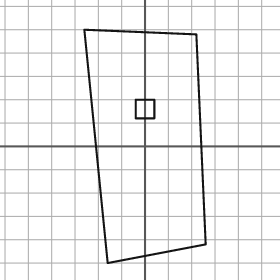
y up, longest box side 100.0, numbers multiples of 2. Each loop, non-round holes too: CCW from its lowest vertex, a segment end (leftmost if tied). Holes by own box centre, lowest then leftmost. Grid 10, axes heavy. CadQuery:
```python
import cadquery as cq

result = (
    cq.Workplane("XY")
    .moveTo(-16.0, -50.0)
    .lineTo(26.0, -42.0)
    .lineTo(22.0, 48.0)
    .lineTo(-26.0, 50.0)
    .close()
    .moveTo(-4.0, 12.0)
    .lineTo(4.0, 12.0)
    .lineTo(4.0, 20.0)
    .lineTo(-4.0, 20.0)
    .close()
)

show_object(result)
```